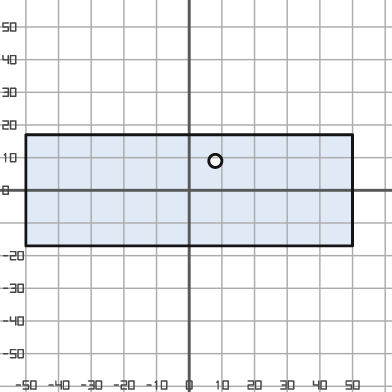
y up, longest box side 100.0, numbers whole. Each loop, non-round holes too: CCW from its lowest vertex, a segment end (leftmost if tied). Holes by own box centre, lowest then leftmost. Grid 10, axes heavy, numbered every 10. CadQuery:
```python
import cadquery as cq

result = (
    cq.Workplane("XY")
    .moveTo(-50.0, -17.0)
    .lineTo(50.0, -17.0)
    .lineTo(50.0, 17.0)
    .lineTo(-50.0, 17.0)
    .close()
    .moveTo(8.0, 9.0)
    .circle(2.0)
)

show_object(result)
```